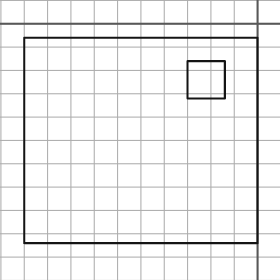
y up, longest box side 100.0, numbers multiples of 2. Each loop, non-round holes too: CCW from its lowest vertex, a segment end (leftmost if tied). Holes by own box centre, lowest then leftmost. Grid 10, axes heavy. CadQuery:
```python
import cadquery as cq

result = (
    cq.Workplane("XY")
    .moveTo(-100.0, -94.0)
    .lineTo(0.0, -94.0)
    .lineTo(0.0, -6.0)
    .lineTo(-100.0, -6.0)
    .close()
    .moveTo(-30.0, -32.0)
    .lineTo(-14.0, -32.0)
    .lineTo(-14.0, -16.0)
    .lineTo(-30.0, -16.0)
    .close()
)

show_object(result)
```